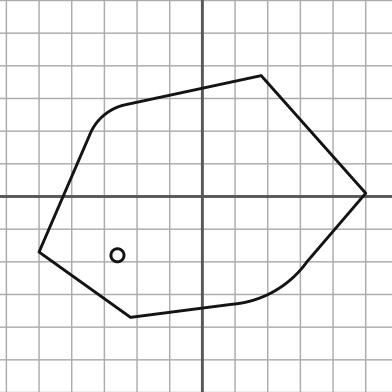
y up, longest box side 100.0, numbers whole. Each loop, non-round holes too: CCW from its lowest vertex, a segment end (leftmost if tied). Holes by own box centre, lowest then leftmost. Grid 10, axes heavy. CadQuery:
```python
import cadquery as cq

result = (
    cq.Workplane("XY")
    .moveTo(-22.0, -37.0)
    .lineTo(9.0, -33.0)
    .threePointArc((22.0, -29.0), (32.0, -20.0))
    .lineTo(50.0, 1.0)
    .lineTo(18.0, 37.0)
    .lineTo(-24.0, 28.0)
    .threePointArc((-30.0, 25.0), (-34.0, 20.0))
    .lineTo(-50.0, -17.0)
    .close()
    .moveTo(-26.0, -18.0)
    .circle(2.0)
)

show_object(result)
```